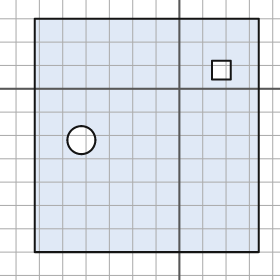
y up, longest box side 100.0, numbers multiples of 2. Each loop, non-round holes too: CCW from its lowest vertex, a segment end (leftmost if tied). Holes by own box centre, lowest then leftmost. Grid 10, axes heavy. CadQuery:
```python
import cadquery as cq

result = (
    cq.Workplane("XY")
    .moveTo(-62.0, -70.0)
    .lineTo(34.0, -70.0)
    .lineTo(34.0, 30.0)
    .lineTo(-62.0, 30.0)
    .close()
    .moveTo(-42.0, -22.0)
    .circle(6.0)
    .moveTo(14.0, 4.0)
    .lineTo(22.0, 4.0)
    .lineTo(22.0, 12.0)
    .lineTo(14.0, 12.0)
    .close()
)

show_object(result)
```